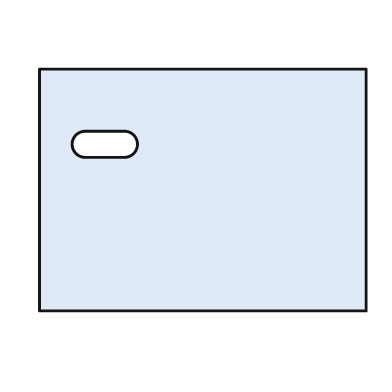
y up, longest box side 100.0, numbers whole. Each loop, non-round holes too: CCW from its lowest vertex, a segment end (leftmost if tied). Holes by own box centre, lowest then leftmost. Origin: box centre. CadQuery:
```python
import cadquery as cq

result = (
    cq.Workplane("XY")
    .moveTo(-50.0, -37.0)
    .lineTo(50.0, -37.0)
    .lineTo(50.0, 37.0)
    .lineTo(-50.0, 37.0)
    .close()
    .moveTo(-36.0, 10.0)
    .lineTo(-24.0, 10.0)
    .threePointArc((-20.0, 14.0), (-24.0, 18.0))
    .lineTo(-36.0, 18.0)
    .threePointArc((-40.0, 14.0), (-36.0, 10.0))
    .close()
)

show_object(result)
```